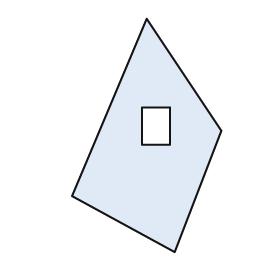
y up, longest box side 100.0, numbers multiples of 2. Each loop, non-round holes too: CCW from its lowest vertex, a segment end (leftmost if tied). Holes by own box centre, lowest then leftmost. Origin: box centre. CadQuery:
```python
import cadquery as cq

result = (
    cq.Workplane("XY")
    .moveTo(12.0, -50.0)
    .lineTo(32.0, 2.0)
    .lineTo(0.0, 50.0)
    .lineTo(-32.0, -26.0)
    .close()
    .moveTo(-2.0, -4.0)
    .lineTo(10.0, -4.0)
    .lineTo(10.0, 12.0)
    .lineTo(-2.0, 12.0)
    .close()
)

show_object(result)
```